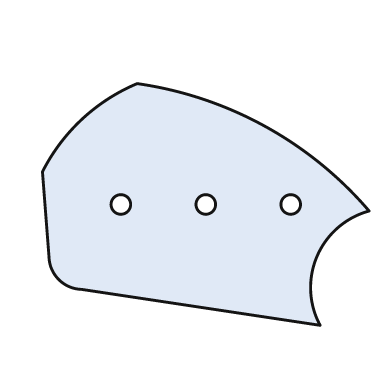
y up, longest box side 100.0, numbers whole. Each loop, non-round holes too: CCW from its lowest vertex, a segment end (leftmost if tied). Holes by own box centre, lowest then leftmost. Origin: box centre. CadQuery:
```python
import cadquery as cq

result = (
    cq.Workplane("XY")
    .moveTo(35.0, -37.0)
    .threePointArc((34.0, -16.0), (50.0, -2.0))
    .threePointArc((18.0, 24.0), (-21.0, 37.0))
    .threePointArc((-38.0, 26.0), (-50.0, 10.0))
    .lineTo(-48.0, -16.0)
    .threePointArc((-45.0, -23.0), (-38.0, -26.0))
    .close()
    .moveTo(-26.0, 0.0)
    .circle(3.0)
    .moveTo(0.0, 0.0)
    .circle(3.0)
    .moveTo(26.0, 0.0)
    .circle(3.0)
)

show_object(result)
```